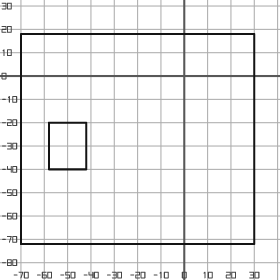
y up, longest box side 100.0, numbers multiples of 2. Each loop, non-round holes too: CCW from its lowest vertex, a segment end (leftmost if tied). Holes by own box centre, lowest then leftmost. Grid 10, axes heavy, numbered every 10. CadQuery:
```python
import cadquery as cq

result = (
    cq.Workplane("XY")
    .moveTo(-70.0, -72.0)
    .lineTo(30.0, -72.0)
    .lineTo(30.0, 18.0)
    .lineTo(-70.0, 18.0)
    .close()
    .moveTo(-58.0, -40.0)
    .lineTo(-42.0, -40.0)
    .lineTo(-42.0, -20.0)
    .lineTo(-58.0, -20.0)
    .close()
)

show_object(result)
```